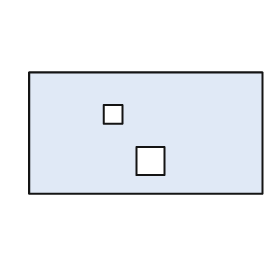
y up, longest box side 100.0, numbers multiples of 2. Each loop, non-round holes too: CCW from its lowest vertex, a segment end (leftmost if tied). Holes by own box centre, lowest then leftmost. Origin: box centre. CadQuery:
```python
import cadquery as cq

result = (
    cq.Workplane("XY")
    .moveTo(-50.0, -26.0)
    .lineTo(50.0, -26.0)
    .lineTo(50.0, 26.0)
    .lineTo(-50.0, 26.0)
    .close()
    .moveTo(-4.0, -18.0)
    .lineTo(8.0, -18.0)
    .lineTo(8.0, -6.0)
    .lineTo(-4.0, -6.0)
    .close()
    .moveTo(-18.0, 4.0)
    .lineTo(-10.0, 4.0)
    .lineTo(-10.0, 12.0)
    .lineTo(-18.0, 12.0)
    .close()
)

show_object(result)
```